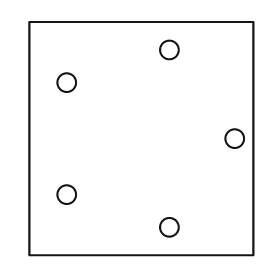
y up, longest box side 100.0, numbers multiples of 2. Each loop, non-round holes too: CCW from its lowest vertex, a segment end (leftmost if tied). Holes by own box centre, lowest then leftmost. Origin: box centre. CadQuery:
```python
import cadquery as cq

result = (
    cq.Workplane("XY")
    .moveTo(-48.0, -50.0)
    .lineTo(48.0, -50.0)
    .lineTo(48.0, 50.0)
    .lineTo(-48.0, 50.0)
    .close()
    .moveTo(12.0, -38.0)
    .circle(4.0)
    .moveTo(-32.0, -24.0)
    .circle(4.0)
    .moveTo(40.0, 0.0)
    .circle(4.0)
    .moveTo(-32.0, 24.0)
    .circle(4.0)
    .moveTo(12.0, 38.0)
    .circle(4.0)
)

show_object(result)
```